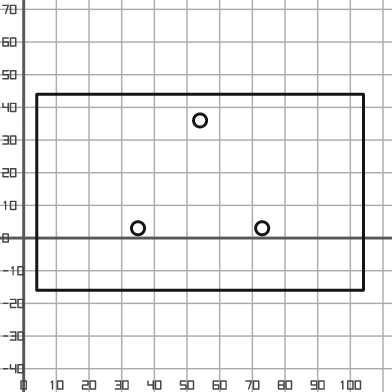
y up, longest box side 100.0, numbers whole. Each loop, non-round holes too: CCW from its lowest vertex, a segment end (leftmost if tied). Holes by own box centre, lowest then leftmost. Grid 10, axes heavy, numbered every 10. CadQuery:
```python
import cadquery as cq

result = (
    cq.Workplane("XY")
    .moveTo(4.0, -16.0)
    .lineTo(104.0, -16.0)
    .lineTo(104.0, 44.0)
    .lineTo(4.0, 44.0)
    .close()
    .moveTo(35.0, 3.0)
    .circle(2.0)
    .moveTo(73.0, 3.0)
    .circle(2.0)
    .moveTo(54.0, 36.0)
    .circle(2.0)
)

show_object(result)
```